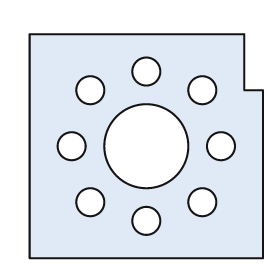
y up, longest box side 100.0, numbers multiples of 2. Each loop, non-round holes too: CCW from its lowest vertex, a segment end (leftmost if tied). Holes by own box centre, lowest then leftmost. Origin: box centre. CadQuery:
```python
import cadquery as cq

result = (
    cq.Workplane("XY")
    .moveTo(-50.0, -48.0)
    .lineTo(50.0, -48.0)
    .lineTo(50.0, 24.0)
    .lineTo(42.0, 24.0)
    .lineTo(42.0, 48.0)
    .lineTo(-50.0, 48.0)
    .close()
    .moveTo(0.0, -32.0)
    .circle(6.0)
    .moveTo(-24.0, -24.0)
    .circle(6.0)
    .moveTo(24.0, -24.0)
    .circle(6.0)
    .moveTo(-32.0, 0.0)
    .circle(6.0)
    .moveTo(0.0, 0.0)
    .circle(18.0)
    .moveTo(32.0, 0.0)
    .circle(6.0)
    .moveTo(-24.0, 24.0)
    .circle(6.0)
    .moveTo(24.0, 24.0)
    .circle(6.0)
    .moveTo(0.0, 32.0)
    .circle(6.0)
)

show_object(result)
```